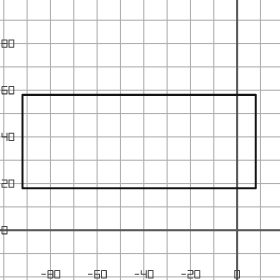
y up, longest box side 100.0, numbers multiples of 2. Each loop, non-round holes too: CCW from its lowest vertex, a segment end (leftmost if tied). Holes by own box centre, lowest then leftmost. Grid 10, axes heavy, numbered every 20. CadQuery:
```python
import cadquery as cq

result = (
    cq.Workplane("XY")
    .moveTo(-92.0, 18.0)
    .lineTo(8.0, 18.0)
    .lineTo(8.0, 58.0)
    .lineTo(-92.0, 58.0)
    .close()
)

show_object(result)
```